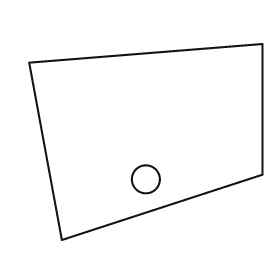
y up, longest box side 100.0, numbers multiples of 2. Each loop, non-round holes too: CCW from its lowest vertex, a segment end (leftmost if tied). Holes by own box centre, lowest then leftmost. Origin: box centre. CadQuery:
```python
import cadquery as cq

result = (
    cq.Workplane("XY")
    .moveTo(-36.0, -42.0)
    .lineTo(50.0, -14.0)
    .lineTo(50.0, 42.0)
    .lineTo(-50.0, 34.0)
    .close()
    .moveTo(0.0, -16.0)
    .circle(6.0)
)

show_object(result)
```